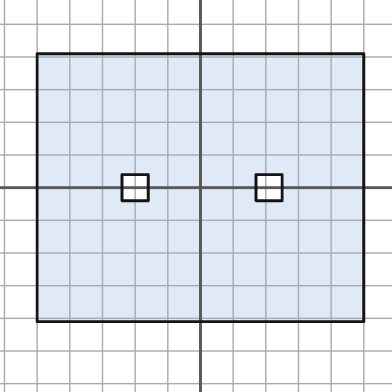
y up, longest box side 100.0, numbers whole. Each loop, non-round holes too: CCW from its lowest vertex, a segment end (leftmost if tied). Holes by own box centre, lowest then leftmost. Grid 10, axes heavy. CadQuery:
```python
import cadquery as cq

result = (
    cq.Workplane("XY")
    .moveTo(-50.0, -41.0)
    .lineTo(50.0, -41.0)
    .lineTo(50.0, 41.0)
    .lineTo(-50.0, 41.0)
    .close()
    .moveTo(-24.0, -4.0)
    .lineTo(-16.0, -4.0)
    .lineTo(-16.0, 4.0)
    .lineTo(-24.0, 4.0)
    .close()
    .moveTo(17.0, -4.0)
    .lineTo(25.0, -4.0)
    .lineTo(25.0, 4.0)
    .lineTo(17.0, 4.0)
    .close()
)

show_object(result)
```